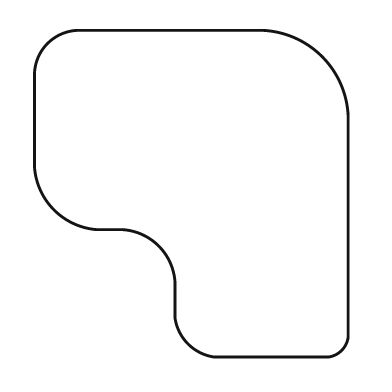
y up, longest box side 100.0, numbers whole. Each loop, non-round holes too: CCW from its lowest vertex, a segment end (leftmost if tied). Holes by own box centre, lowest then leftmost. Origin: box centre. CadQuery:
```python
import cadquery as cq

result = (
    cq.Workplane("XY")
    .moveTo(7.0, -50.0)
    .lineTo(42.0, -50.0)
    .threePointArc((46.0, -48.0), (48.0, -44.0))
    .lineTo(48.0, 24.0)
    .threePointArc((40.0, 42.0), (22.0, 50.0))
    .lineTo(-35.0, 50.0)
    .threePointArc((-44.0, 46.0), (-48.0, 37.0))
    .lineTo(-48.0, 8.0)
    .threePointArc((-42.0, -5.0), (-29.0, -11.0))
    .lineTo(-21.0, -11.0)
    .threePointArc((-10.0, -16.0), (-5.0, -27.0))
    .lineTo(-5.0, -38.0)
    .threePointArc((-1.0, -46.0), (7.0, -50.0))
    .close()
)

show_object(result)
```